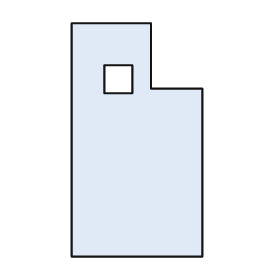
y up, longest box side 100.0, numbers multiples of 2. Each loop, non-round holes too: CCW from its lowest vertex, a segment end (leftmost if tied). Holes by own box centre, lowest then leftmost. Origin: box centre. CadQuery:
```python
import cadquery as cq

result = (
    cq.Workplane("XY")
    .moveTo(-28.0, -50.0)
    .lineTo(28.0, -50.0)
    .lineTo(28.0, 22.0)
    .lineTo(6.0, 22.0)
    .lineTo(6.0, 50.0)
    .lineTo(-28.0, 50.0)
    .close()
    .moveTo(-14.0, 20.0)
    .lineTo(-2.0, 20.0)
    .lineTo(-2.0, 32.0)
    .lineTo(-14.0, 32.0)
    .close()
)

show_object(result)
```